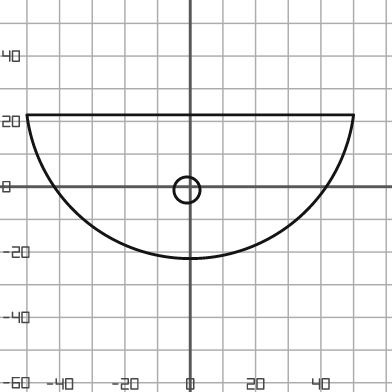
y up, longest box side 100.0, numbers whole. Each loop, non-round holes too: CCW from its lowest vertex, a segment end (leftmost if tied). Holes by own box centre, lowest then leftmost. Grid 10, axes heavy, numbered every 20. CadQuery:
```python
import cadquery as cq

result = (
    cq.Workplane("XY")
    .moveTo(-50.0, 22.0)
    .threePointArc((0.0, -22.0), (50.0, 22.0))
    .close()
    .moveTo(-1.0, -1.0)
    .circle(4.0)
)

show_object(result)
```